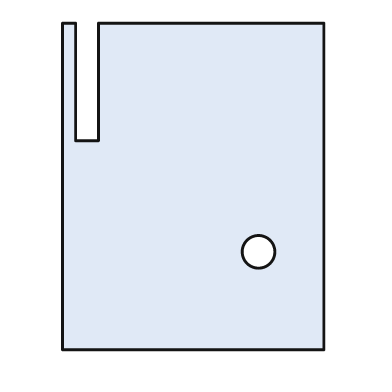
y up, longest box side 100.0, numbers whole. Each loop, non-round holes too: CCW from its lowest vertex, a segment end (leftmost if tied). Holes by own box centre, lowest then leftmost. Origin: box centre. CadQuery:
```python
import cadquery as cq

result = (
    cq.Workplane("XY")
    .moveTo(-40.0, -50.0)
    .lineTo(40.0, -50.0)
    .lineTo(40.0, 50.0)
    .lineTo(-29.0, 50.0)
    .lineTo(-29.0, 14.0)
    .lineTo(-36.0, 14.0)
    .lineTo(-36.0, 50.0)
    .lineTo(-40.0, 50.0)
    .close()
    .moveTo(20.0, -20.0)
    .circle(5.0)
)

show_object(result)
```